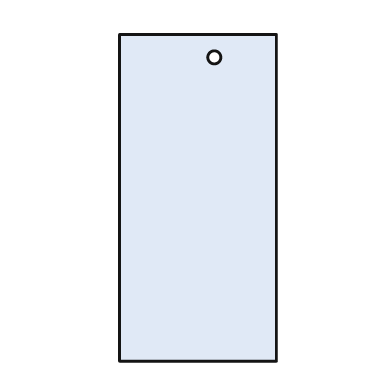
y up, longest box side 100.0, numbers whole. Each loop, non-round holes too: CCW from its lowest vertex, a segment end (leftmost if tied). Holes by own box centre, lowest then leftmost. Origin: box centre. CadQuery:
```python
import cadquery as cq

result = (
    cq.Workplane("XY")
    .moveTo(-24.0, -50.0)
    .lineTo(24.0, -50.0)
    .lineTo(24.0, 50.0)
    .lineTo(-24.0, 50.0)
    .close()
    .moveTo(5.0, 43.0)
    .circle(2.0)
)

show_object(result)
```